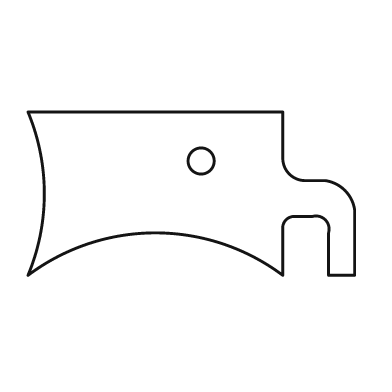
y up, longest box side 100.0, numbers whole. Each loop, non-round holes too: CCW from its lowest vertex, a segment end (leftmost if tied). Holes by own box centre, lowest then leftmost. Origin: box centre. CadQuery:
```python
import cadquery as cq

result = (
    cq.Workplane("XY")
    .moveTo(-50.0, -25.0)
    .threePointArc((-11.0, -12.0), (28.0, -25.0))
    .lineTo(28.0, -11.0)
    .threePointArc((29.0, -8.0), (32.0, -7.0))
    .lineTo(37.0, -7.0)
    .threePointArc((41.0, -8.0), (42.0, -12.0))
    .lineTo(42.0, -25.0)
    .lineTo(50.0, -25.0)
    .lineTo(50.0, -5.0)
    .threePointArc((47.0, 1.0), (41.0, 4.0))
    .lineTo(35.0, 4.0)
    .threePointArc((30.0, 6.0), (28.0, 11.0))
    .lineTo(28.0, 25.0)
    .lineTo(-50.0, 25.0)
    .threePointArc((-45.0, 0.0), (-50.0, -25.0))
    .close()
    .moveTo(3.0, 10.0)
    .circle(4.0)
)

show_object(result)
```